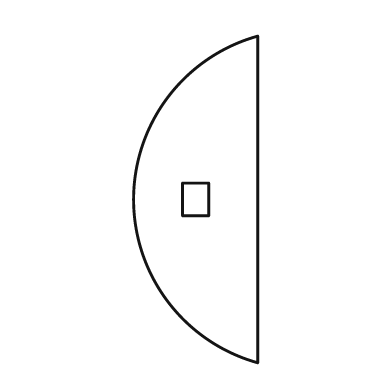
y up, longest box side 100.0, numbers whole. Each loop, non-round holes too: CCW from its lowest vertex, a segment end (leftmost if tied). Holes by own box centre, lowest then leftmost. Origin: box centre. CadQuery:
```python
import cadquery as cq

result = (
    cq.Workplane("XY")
    .moveTo(19.0, -50.0)
    .lineTo(19.0, 50.0)
    .threePointArc((-19.0, 0.0), (19.0, -50.0))
    .close()
    .moveTo(-4.0, -5.0)
    .lineTo(4.0, -5.0)
    .lineTo(4.0, 5.0)
    .lineTo(-4.0, 5.0)
    .close()
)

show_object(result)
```